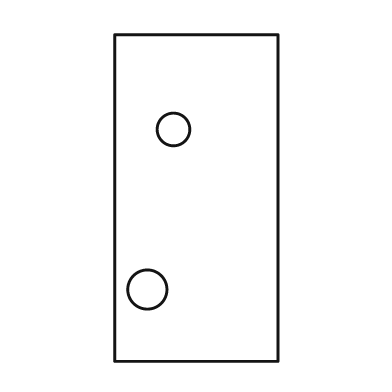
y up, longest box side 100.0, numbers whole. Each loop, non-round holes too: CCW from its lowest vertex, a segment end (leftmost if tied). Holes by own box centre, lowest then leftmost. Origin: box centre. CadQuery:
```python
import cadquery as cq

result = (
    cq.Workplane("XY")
    .moveTo(-25.0, -50.0)
    .lineTo(25.0, -50.0)
    .lineTo(25.0, 50.0)
    .lineTo(-25.0, 50.0)
    .close()
    .moveTo(-15.0, -28.0)
    .circle(6.0)
    .moveTo(-7.0, 21.0)
    .circle(5.0)
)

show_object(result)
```